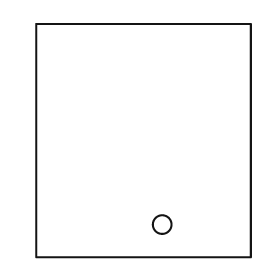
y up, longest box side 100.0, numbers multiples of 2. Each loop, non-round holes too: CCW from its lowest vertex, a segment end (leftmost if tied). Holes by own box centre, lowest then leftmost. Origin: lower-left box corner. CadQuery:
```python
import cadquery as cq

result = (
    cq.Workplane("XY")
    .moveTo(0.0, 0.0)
    .lineTo(92.0, 0.0)
    .lineTo(92.0, 100.0)
    .lineTo(0.0, 100.0)
    .close()
    .moveTo(54.0, 14.0)
    .circle(4.0)
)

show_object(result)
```